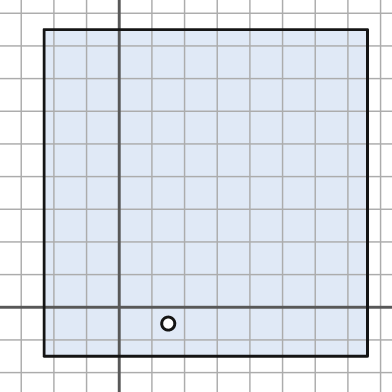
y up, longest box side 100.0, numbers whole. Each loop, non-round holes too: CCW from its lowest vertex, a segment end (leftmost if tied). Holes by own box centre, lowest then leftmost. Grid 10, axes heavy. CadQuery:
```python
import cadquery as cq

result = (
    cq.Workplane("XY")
    .moveTo(-23.0, -15.0)
    .lineTo(76.0, -15.0)
    .lineTo(76.0, 85.0)
    .lineTo(-23.0, 85.0)
    .close()
    .moveTo(15.0, -5.0)
    .circle(2.0)
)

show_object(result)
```